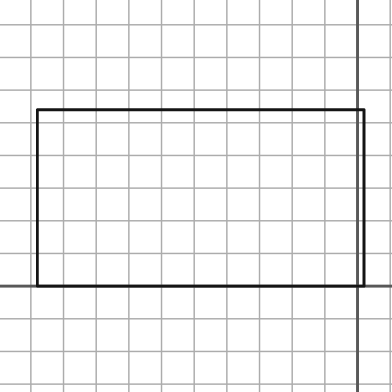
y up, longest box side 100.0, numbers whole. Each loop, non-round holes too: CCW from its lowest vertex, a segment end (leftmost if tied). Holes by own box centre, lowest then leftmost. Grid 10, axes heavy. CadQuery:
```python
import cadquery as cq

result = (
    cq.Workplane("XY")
    .moveTo(-98.0, 0.0)
    .lineTo(2.0, 0.0)
    .lineTo(2.0, 54.0)
    .lineTo(-98.0, 54.0)
    .close()
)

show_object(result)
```